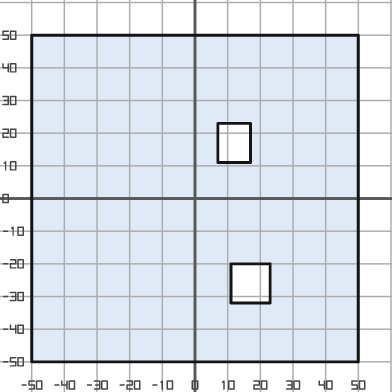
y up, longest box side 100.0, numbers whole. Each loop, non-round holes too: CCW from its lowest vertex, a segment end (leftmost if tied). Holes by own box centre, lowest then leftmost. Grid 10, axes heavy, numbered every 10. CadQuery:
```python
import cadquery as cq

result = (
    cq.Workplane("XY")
    .moveTo(-50.0, -50.0)
    .lineTo(50.0, -50.0)
    .lineTo(50.0, 50.0)
    .lineTo(-50.0, 50.0)
    .close()
    .moveTo(11.0, -32.0)
    .lineTo(23.0, -32.0)
    .lineTo(23.0, -20.0)
    .lineTo(11.0, -20.0)
    .close()
    .moveTo(7.0, 11.0)
    .lineTo(17.0, 11.0)
    .lineTo(17.0, 23.0)
    .lineTo(7.0, 23.0)
    .close()
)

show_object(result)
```